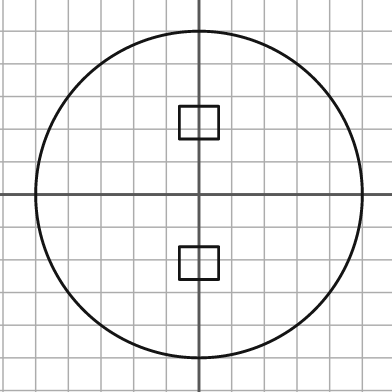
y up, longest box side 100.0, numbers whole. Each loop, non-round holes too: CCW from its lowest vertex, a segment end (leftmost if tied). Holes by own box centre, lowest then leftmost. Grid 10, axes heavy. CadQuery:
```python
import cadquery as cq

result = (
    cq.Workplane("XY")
    .moveTo(0.0, 0.0)
    .circle(50.0)
    .moveTo(-6.0, -26.0)
    .lineTo(6.0, -26.0)
    .lineTo(6.0, -16.0)
    .lineTo(-6.0, -16.0)
    .close()
    .moveTo(-6.0, 17.0)
    .lineTo(6.0, 17.0)
    .lineTo(6.0, 27.0)
    .lineTo(-6.0, 27.0)
    .close()
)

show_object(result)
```